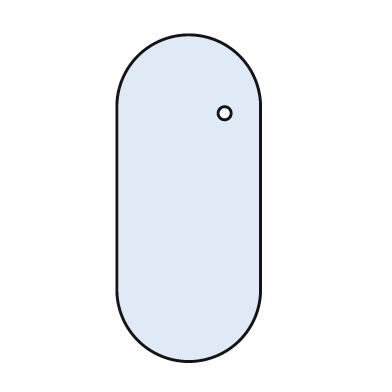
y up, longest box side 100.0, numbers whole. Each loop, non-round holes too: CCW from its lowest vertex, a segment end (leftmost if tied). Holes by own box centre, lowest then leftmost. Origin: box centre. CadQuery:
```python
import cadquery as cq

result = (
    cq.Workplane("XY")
    .moveTo(-22.0, -28.0)
    .threePointArc((0.0, -50.0), (22.0, -28.0))
    .lineTo(22.0, 28.0)
    .threePointArc((0.0, 50.0), (-22.0, 28.0))
    .close()
    .moveTo(11.0, 26.0)
    .circle(2.0)
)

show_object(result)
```